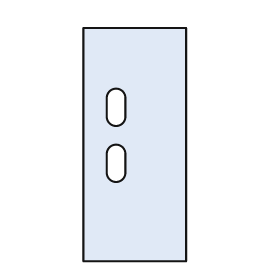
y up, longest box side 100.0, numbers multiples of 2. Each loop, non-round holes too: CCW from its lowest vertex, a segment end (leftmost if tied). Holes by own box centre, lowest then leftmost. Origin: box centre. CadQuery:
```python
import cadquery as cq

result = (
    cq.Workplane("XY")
    .moveTo(-22.0, -50.0)
    .lineTo(22.0, -50.0)
    .lineTo(22.0, 50.0)
    .lineTo(-22.0, 50.0)
    .close()
    .moveTo(-12.0, -12.0)
    .threePointArc((-8.0, -16.0), (-4.0, -12.0))
    .lineTo(-4.0, -4.0)
    .threePointArc((-8.0, 0.0), (-12.0, -4.0))
    .close()
    .moveTo(-12.0, 12.0)
    .threePointArc((-8.0, 8.0), (-4.0, 12.0))
    .lineTo(-4.0, 20.0)
    .threePointArc((-8.0, 24.0), (-12.0, 20.0))
    .close()
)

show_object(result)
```